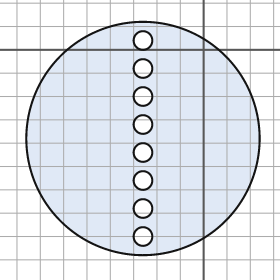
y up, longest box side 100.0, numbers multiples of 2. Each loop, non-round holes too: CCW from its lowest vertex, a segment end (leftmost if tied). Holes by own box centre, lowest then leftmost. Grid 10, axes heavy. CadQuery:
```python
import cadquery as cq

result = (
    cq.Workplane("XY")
    .moveTo(-26.0, -38.0)
    .circle(50.0)
    .moveTo(-26.0, -80.0)
    .circle(4.0)
    .moveTo(-26.0, -68.0)
    .circle(4.0)
    .moveTo(-26.0, -56.0)
    .circle(4.0)
    .moveTo(-26.0, -44.0)
    .circle(4.0)
    .moveTo(-26.0, -32.0)
    .circle(4.0)
    .moveTo(-26.0, -20.0)
    .circle(4.0)
    .moveTo(-26.0, -8.0)
    .circle(4.0)
    .moveTo(-26.0, 4.0)
    .circle(4.0)
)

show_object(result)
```